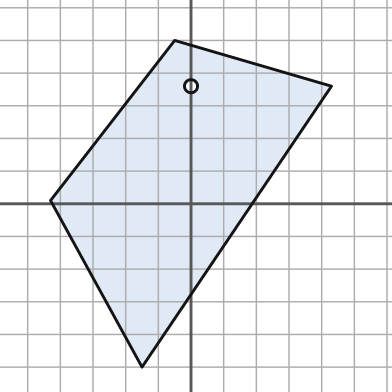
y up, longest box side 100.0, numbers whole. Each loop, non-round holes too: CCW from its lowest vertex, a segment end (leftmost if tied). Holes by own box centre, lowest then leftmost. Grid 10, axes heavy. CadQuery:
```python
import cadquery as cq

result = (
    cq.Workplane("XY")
    .moveTo(-15.0, -50.0)
    .lineTo(43.0, 36.0)
    .lineTo(-5.0, 50.0)
    .lineTo(-43.0, 1.0)
    .close()
    .moveTo(0.0, 36.0)
    .circle(2.0)
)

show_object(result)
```